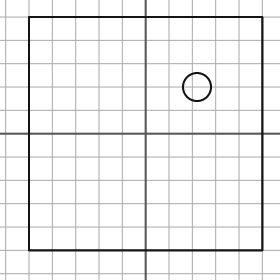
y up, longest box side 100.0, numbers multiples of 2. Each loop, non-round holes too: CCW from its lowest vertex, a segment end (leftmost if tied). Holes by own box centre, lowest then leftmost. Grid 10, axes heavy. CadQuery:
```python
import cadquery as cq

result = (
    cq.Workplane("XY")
    .moveTo(-50.0, -50.0)
    .lineTo(50.0, -50.0)
    .lineTo(50.0, 50.0)
    .lineTo(-50.0, 50.0)
    .close()
    .moveTo(22.0, 20.0)
    .circle(6.0)
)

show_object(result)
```